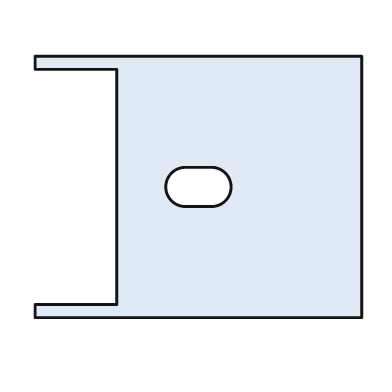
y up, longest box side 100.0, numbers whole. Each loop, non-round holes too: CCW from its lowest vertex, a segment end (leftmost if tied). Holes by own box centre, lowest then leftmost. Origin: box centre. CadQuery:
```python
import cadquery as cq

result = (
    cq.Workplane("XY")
    .moveTo(-50.0, -40.0)
    .lineTo(50.0, -40.0)
    .lineTo(50.0, 40.0)
    .lineTo(-50.0, 40.0)
    .lineTo(-50.0, 36.0)
    .lineTo(-25.0, 36.0)
    .lineTo(-25.0, -36.0)
    .lineTo(-50.0, -36.0)
    .close()
    .moveTo(-4.0, -6.0)
    .lineTo(4.0, -6.0)
    .threePointArc((10.0, 0.0), (4.0, 6.0))
    .lineTo(-4.0, 6.0)
    .threePointArc((-10.0, 0.0), (-4.0, -6.0))
    .close()
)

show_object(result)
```